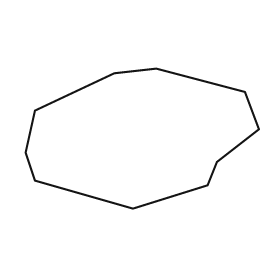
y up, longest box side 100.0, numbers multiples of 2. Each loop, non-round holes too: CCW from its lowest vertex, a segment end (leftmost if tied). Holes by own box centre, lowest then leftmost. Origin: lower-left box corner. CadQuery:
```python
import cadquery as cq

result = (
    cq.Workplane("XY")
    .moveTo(46.0, 0.0)
    .lineTo(78.0, 10.0)
    .lineTo(82.0, 20.0)
    .lineTo(100.0, 34.0)
    .lineTo(94.0, 50.0)
    .lineTo(56.0, 60.0)
    .lineTo(38.0, 58.0)
    .lineTo(4.0, 42.0)
    .lineTo(0.0, 24.0)
    .lineTo(4.0, 12.0)
    .close()
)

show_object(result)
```